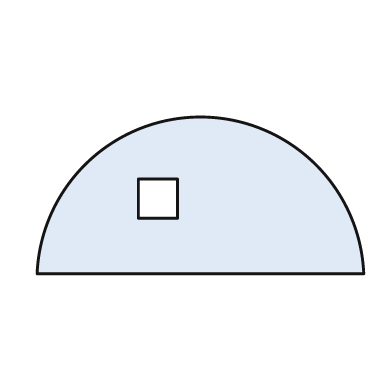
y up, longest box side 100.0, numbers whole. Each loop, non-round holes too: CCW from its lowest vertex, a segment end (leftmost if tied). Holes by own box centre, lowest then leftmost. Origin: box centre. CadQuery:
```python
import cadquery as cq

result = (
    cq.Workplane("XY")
    .moveTo(-50.0, -24.0)
    .lineTo(50.0, -24.0)
    .threePointArc((0.0, 24.0), (-50.0, -24.0))
    .close()
    .moveTo(-19.0, -7.0)
    .lineTo(-7.0, -7.0)
    .lineTo(-7.0, 5.0)
    .lineTo(-19.0, 5.0)
    .close()
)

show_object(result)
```